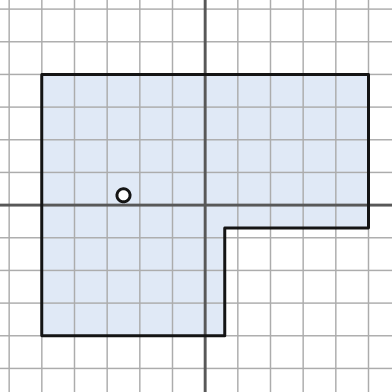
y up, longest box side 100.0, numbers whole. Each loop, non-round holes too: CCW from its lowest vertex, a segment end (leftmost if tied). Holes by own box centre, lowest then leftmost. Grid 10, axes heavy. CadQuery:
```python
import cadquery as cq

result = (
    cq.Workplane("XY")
    .moveTo(-50.0, -40.0)
    .lineTo(6.0, -40.0)
    .lineTo(6.0, -7.0)
    .lineTo(50.0, -7.0)
    .lineTo(50.0, 40.0)
    .lineTo(-50.0, 40.0)
    .close()
    .moveTo(-25.0, 3.0)
    .circle(2.0)
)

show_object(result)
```